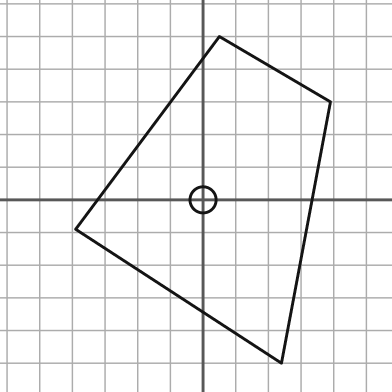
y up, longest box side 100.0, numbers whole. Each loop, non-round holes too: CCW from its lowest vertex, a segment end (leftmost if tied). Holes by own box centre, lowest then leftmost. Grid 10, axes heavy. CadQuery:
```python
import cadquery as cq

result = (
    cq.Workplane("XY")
    .moveTo(24.0, -50.0)
    .lineTo(39.0, 30.0)
    .lineTo(5.0, 50.0)
    .lineTo(-39.0, -9.0)
    .close()
    .moveTo(0.0, 0.0)
    .circle(4.0)
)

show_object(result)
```